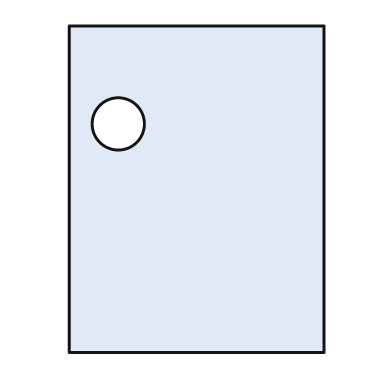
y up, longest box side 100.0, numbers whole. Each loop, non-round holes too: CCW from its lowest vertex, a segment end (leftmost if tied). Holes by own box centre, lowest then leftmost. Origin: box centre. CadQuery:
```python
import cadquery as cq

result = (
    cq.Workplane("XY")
    .moveTo(-39.0, -50.0)
    .lineTo(39.0, -50.0)
    .lineTo(39.0, 50.0)
    .lineTo(-39.0, 50.0)
    .close()
    .moveTo(-24.0, 20.0)
    .circle(8.0)
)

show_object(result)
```